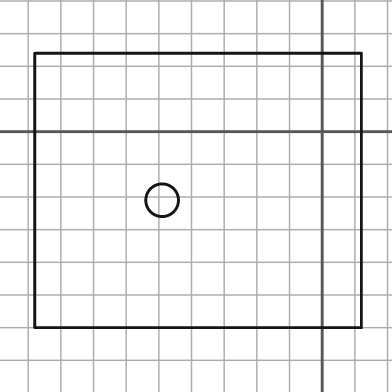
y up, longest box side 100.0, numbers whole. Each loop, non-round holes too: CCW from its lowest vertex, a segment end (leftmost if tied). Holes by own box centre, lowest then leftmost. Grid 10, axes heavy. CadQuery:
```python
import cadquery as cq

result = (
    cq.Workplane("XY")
    .moveTo(-88.0, -60.0)
    .lineTo(12.0, -60.0)
    .lineTo(12.0, 24.0)
    .lineTo(-88.0, 24.0)
    .close()
    .moveTo(-49.0, -21.0)
    .circle(5.0)
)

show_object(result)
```